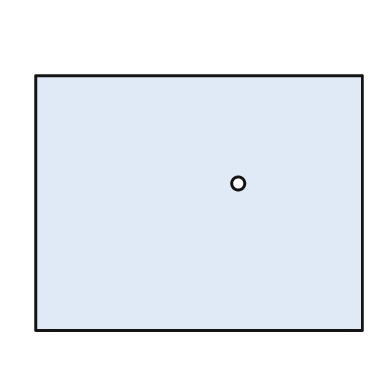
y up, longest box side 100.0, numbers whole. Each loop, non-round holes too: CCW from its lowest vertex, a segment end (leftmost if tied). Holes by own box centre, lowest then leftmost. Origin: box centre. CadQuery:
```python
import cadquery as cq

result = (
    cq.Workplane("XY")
    .moveTo(-50.0, -39.0)
    .lineTo(50.0, -39.0)
    .lineTo(50.0, 39.0)
    .lineTo(-50.0, 39.0)
    .close()
    .moveTo(12.0, 6.0)
    .circle(2.0)
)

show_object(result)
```